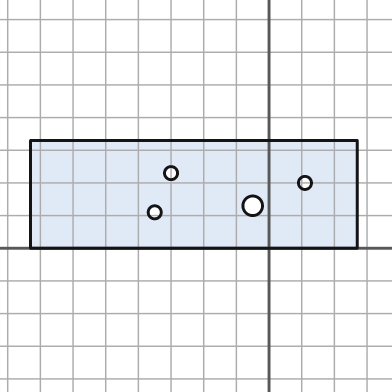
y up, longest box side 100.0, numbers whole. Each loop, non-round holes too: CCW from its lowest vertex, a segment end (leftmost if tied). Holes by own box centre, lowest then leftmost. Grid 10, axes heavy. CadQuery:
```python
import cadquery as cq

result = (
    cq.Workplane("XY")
    .moveTo(-73.0, 0.0)
    .lineTo(27.0, 0.0)
    .lineTo(27.0, 33.0)
    .lineTo(-73.0, 33.0)
    .close()
    .moveTo(-35.0, 11.0)
    .circle(2.0)
    .moveTo(-5.0, 13.0)
    .circle(3.0)
    .moveTo(11.0, 20.0)
    .circle(2.0)
    .moveTo(-30.0, 23.0)
    .circle(2.0)
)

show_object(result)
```